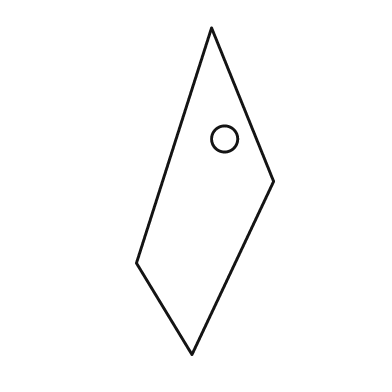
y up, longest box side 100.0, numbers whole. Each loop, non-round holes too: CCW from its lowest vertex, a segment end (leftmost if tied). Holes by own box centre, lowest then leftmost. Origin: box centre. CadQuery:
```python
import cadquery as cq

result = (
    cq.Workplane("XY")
    .moveTo(-4.0, -50.0)
    .lineTo(21.0, 3.0)
    .lineTo(2.0, 50.0)
    .lineTo(-21.0, -22.0)
    .close()
    .moveTo(6.0, 16.0)
    .circle(4.0)
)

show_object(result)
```